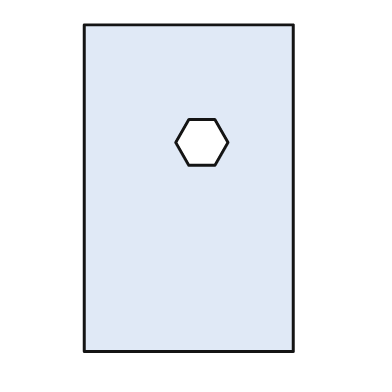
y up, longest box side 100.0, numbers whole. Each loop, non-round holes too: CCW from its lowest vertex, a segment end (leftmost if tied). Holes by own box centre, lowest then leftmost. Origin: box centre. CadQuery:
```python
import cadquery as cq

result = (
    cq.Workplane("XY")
    .moveTo(-32.0, -50.0)
    .lineTo(32.0, -50.0)
    .lineTo(32.0, 50.0)
    .lineTo(-32.0, 50.0)
    .close()
    .moveTo(0.0, 7.0)
    .lineTo(8.0, 7.0)
    .lineTo(12.0, 14.0)
    .lineTo(8.0, 21.0)
    .lineTo(0.0, 21.0)
    .lineTo(-4.0, 14.0)
    .close()
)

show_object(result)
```